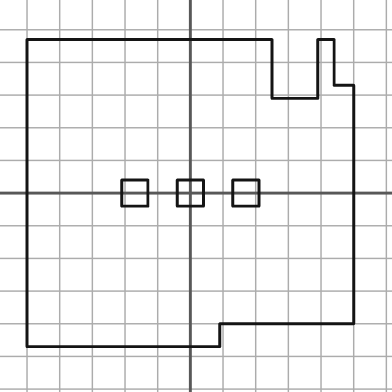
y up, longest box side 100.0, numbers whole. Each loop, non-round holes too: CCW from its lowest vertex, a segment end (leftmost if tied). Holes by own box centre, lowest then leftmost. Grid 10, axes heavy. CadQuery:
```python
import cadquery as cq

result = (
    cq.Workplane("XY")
    .moveTo(-50.0, -47.0)
    .lineTo(9.0, -47.0)
    .lineTo(9.0, -40.0)
    .lineTo(50.0, -40.0)
    .lineTo(50.0, 33.0)
    .lineTo(44.0, 33.0)
    .lineTo(44.0, 47.0)
    .lineTo(39.0, 47.0)
    .lineTo(39.0, 29.0)
    .lineTo(25.0, 29.0)
    .lineTo(25.0, 47.0)
    .lineTo(-50.0, 47.0)
    .close()
    .moveTo(-21.0, -4.0)
    .lineTo(-13.0, -4.0)
    .lineTo(-13.0, 4.0)
    .lineTo(-21.0, 4.0)
    .close()
    .moveTo(-4.0, -4.0)
    .lineTo(4.0, -4.0)
    .lineTo(4.0, 4.0)
    .lineTo(-4.0, 4.0)
    .close()
    .moveTo(13.0, -4.0)
    .lineTo(21.0, -4.0)
    .lineTo(21.0, 4.0)
    .lineTo(13.0, 4.0)
    .close()
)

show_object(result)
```